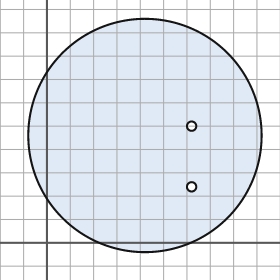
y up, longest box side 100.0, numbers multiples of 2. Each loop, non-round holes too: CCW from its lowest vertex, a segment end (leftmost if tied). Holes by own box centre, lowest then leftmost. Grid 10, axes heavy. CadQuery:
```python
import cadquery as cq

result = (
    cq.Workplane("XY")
    .moveTo(42.0, 46.0)
    .circle(50.0)
    .moveTo(62.0, 24.0)
    .circle(2.0)
    .moveTo(62.0, 50.0)
    .circle(2.0)
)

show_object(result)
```